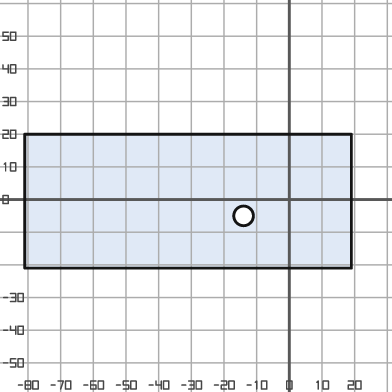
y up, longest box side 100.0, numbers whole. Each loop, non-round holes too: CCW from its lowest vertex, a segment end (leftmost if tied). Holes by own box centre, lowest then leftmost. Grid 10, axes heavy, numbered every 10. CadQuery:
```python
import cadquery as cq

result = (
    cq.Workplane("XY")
    .moveTo(-81.0, -21.0)
    .lineTo(19.0, -21.0)
    .lineTo(19.0, 20.0)
    .lineTo(-81.0, 20.0)
    .close()
    .moveTo(-14.0, -5.0)
    .circle(3.0)
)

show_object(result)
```